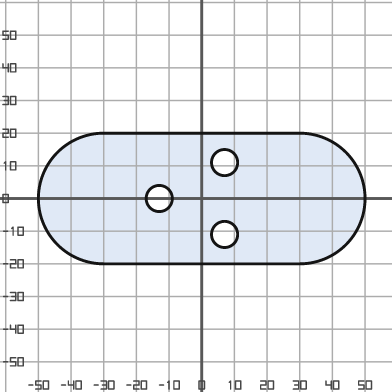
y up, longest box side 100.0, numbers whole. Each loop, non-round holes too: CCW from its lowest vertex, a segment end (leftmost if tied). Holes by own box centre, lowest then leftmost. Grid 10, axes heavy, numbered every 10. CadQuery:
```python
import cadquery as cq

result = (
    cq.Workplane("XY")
    .moveTo(-30.0, -20.0)
    .lineTo(30.0, -20.0)
    .threePointArc((50.0, 0.0), (30.0, 20.0))
    .lineTo(-30.0, 20.0)
    .threePointArc((-50.0, 0.0), (-30.0, -20.0))
    .close()
    .moveTo(7.0, -11.0)
    .circle(4.0)
    .moveTo(-13.0, 0.0)
    .circle(4.0)
    .moveTo(7.0, 11.0)
    .circle(4.0)
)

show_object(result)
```